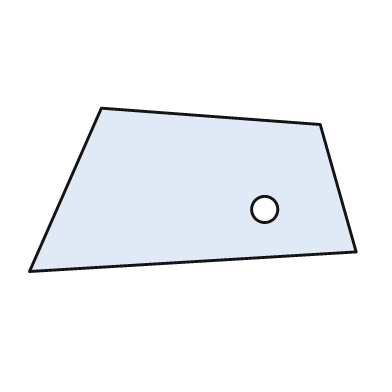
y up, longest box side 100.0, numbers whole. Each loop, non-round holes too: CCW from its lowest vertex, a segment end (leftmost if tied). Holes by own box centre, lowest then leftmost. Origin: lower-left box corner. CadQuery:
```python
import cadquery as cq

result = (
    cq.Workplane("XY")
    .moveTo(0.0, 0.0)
    .lineTo(100.0, 6.0)
    .lineTo(89.0, 45.0)
    .lineTo(22.0, 50.0)
    .close()
    .moveTo(72.0, 19.0)
    .circle(4.0)
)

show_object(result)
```